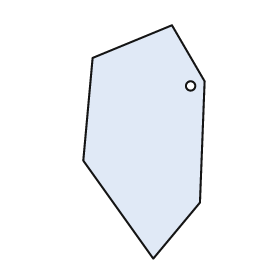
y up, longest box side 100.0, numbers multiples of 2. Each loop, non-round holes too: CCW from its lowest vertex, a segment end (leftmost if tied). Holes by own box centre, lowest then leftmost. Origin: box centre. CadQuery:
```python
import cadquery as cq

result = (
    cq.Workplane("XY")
    .moveTo(4.0, -50.0)
    .lineTo(24.0, -26.0)
    .lineTo(26.0, 26.0)
    .lineTo(12.0, 50.0)
    .lineTo(-22.0, 36.0)
    .lineTo(-26.0, -8.0)
    .close()
    .moveTo(20.0, 24.0)
    .circle(2.0)
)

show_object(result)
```